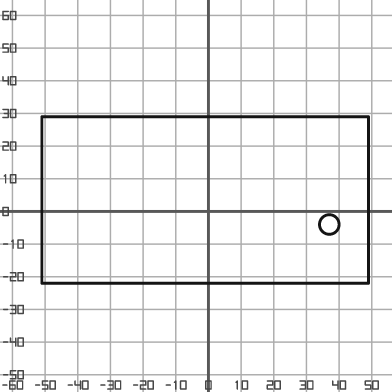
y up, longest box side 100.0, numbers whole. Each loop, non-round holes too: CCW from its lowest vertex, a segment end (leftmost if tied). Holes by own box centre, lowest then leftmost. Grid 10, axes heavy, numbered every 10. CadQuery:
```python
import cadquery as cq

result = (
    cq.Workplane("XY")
    .moveTo(-51.0, -22.0)
    .lineTo(49.0, -22.0)
    .lineTo(49.0, 29.0)
    .lineTo(-51.0, 29.0)
    .close()
    .moveTo(37.0, -4.0)
    .circle(3.0)
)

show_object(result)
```